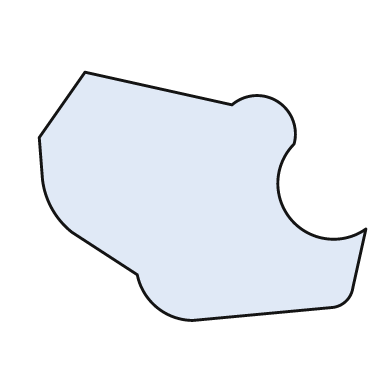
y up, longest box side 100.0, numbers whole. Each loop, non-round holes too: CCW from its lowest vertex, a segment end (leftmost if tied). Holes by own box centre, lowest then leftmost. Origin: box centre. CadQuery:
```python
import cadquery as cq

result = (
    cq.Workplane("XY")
    .moveTo(-3.0, -38.0)
    .lineTo(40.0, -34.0)
    .threePointArc((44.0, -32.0), (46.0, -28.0))
    .lineTo(50.0, -10.0)
    .threePointArc((27.0, -7.0), (28.0, 16.0))
    .threePointArc((23.0, 29.0), (9.0, 28.0))
    .lineTo(-36.0, 38.0)
    .lineTo(-50.0, 18.0)
    .lineTo(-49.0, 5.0)
    .threePointArc((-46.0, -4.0), (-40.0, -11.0))
    .lineTo(-20.0, -24.0)
    .threePointArc((-14.0, -34.0), (-3.0, -38.0))
    .close()
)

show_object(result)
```